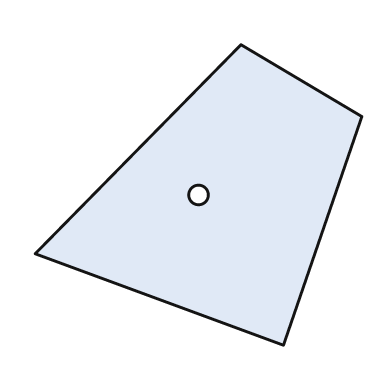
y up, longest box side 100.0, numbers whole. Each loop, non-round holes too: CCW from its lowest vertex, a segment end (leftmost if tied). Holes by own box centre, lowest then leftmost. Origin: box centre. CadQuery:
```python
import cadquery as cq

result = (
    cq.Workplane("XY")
    .moveTo(26.0, -46.0)
    .lineTo(50.0, 24.0)
    .lineTo(13.0, 46.0)
    .lineTo(-50.0, -18.0)
    .close()
    .moveTo(0.0, 0.0)
    .circle(3.0)
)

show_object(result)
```